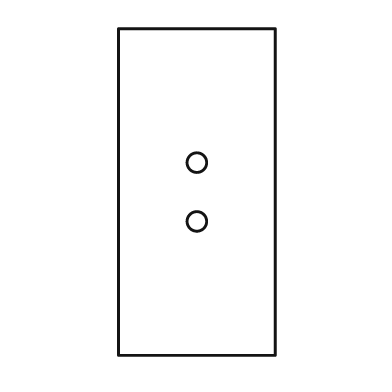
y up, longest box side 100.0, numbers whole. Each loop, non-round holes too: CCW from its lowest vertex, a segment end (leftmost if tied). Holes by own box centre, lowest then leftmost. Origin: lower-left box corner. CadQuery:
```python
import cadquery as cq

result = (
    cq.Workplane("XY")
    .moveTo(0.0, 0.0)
    .lineTo(48.0, 0.0)
    .lineTo(48.0, 100.0)
    .lineTo(0.0, 100.0)
    .close()
    .moveTo(24.0, 41.0)
    .circle(3.0)
    .moveTo(24.0, 59.0)
    .circle(3.0)
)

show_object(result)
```